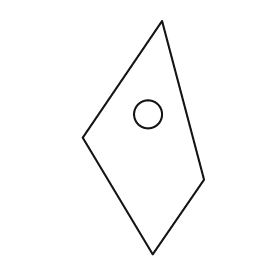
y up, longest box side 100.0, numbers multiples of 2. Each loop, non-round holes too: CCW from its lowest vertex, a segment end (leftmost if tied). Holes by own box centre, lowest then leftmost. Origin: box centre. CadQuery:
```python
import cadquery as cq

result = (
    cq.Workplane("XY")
    .moveTo(4.0, -50.0)
    .lineTo(26.0, -18.0)
    .lineTo(8.0, 50.0)
    .lineTo(-26.0, 0.0)
    .close()
    .moveTo(2.0, 10.0)
    .circle(6.0)
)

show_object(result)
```